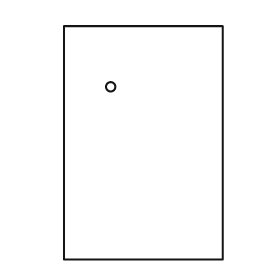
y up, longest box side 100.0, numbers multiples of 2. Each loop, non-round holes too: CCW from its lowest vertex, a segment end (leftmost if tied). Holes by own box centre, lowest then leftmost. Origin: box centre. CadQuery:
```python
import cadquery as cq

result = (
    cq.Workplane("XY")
    .moveTo(-34.0, -50.0)
    .lineTo(34.0, -50.0)
    .lineTo(34.0, 50.0)
    .lineTo(-34.0, 50.0)
    .close()
    .moveTo(-14.0, 24.0)
    .circle(2.0)
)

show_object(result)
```